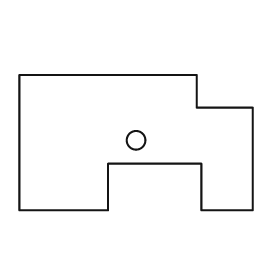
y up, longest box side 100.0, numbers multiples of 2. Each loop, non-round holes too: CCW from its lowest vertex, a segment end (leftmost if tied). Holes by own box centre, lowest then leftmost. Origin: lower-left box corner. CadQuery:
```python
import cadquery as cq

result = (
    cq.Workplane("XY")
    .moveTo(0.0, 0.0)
    .lineTo(38.0, 0.0)
    .lineTo(38.0, 20.0)
    .lineTo(78.0, 20.0)
    .lineTo(78.0, 0.0)
    .lineTo(100.0, 0.0)
    .lineTo(100.0, 44.0)
    .lineTo(76.0, 44.0)
    .lineTo(76.0, 58.0)
    .lineTo(0.0, 58.0)
    .close()
    .moveTo(50.0, 30.0)
    .circle(4.0)
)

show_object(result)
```